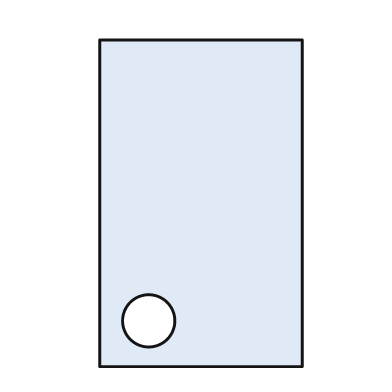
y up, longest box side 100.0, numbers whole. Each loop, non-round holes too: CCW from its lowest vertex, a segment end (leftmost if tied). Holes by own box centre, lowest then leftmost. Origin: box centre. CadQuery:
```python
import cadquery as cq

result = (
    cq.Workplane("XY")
    .moveTo(-31.0, -50.0)
    .lineTo(31.0, -50.0)
    .lineTo(31.0, 50.0)
    .lineTo(-31.0, 50.0)
    .close()
    .moveTo(-16.0, -36.0)
    .circle(8.0)
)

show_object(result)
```